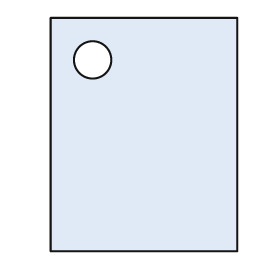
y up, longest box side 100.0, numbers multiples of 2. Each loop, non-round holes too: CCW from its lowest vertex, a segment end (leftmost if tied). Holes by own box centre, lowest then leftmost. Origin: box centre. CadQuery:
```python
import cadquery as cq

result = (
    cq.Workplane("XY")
    .moveTo(-40.0, -50.0)
    .lineTo(40.0, -50.0)
    .lineTo(40.0, 50.0)
    .lineTo(-40.0, 50.0)
    .close()
    .moveTo(-22.0, 32.0)
    .circle(8.0)
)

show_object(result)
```